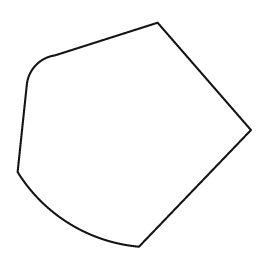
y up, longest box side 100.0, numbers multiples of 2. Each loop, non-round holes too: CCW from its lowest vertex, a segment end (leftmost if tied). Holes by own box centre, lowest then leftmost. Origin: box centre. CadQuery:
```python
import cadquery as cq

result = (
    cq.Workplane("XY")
    .moveTo(2.0, -48.0)
    .lineTo(50.0, 2.0)
    .lineTo(10.0, 48.0)
    .lineTo(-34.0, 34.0)
    .threePointArc((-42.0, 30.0), (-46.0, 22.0))
    .lineTo(-50.0, -16.0)
    .threePointArc((-28.0, -38.0), (2.0, -48.0))
    .close()
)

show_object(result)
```